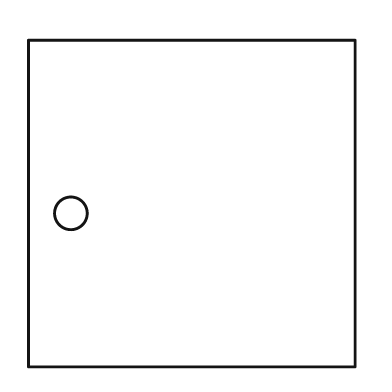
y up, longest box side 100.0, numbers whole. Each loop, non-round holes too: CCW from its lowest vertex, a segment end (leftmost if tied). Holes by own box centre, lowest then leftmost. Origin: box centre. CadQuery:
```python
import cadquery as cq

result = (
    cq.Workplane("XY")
    .moveTo(-50.0, -50.0)
    .lineTo(50.0, -50.0)
    .lineTo(50.0, 50.0)
    .lineTo(-50.0, 50.0)
    .close()
    .moveTo(-37.0, -3.0)
    .circle(5.0)
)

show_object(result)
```